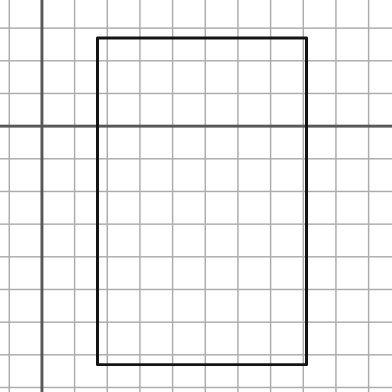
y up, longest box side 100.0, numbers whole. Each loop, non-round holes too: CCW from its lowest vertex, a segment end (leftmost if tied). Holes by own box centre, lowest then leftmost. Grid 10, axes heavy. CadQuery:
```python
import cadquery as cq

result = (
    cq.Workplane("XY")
    .moveTo(17.0, -73.0)
    .lineTo(81.0, -73.0)
    .lineTo(81.0, 27.0)
    .lineTo(17.0, 27.0)
    .close()
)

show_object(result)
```